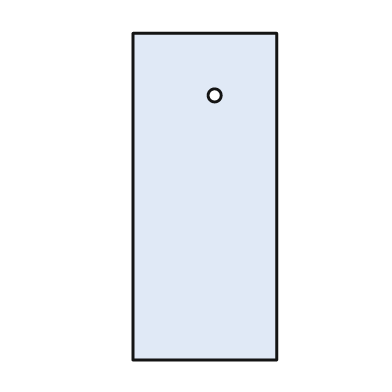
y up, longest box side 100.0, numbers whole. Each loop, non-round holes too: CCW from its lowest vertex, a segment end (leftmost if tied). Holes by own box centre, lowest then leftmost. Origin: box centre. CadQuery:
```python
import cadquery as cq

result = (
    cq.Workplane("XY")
    .moveTo(-22.0, -50.0)
    .lineTo(22.0, -50.0)
    .lineTo(22.0, 50.0)
    .lineTo(-22.0, 50.0)
    .close()
    .moveTo(3.0, 31.0)
    .circle(2.0)
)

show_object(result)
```